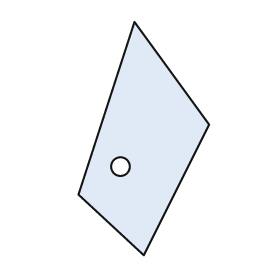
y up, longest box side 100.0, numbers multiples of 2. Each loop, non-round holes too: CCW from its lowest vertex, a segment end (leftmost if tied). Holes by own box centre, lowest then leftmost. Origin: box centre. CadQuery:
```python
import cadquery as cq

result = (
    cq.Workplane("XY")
    .moveTo(0.0, -50.0)
    .lineTo(28.0, 6.0)
    .lineTo(-4.0, 50.0)
    .lineTo(-28.0, -24.0)
    .close()
    .moveTo(-10.0, -12.0)
    .circle(4.0)
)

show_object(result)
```